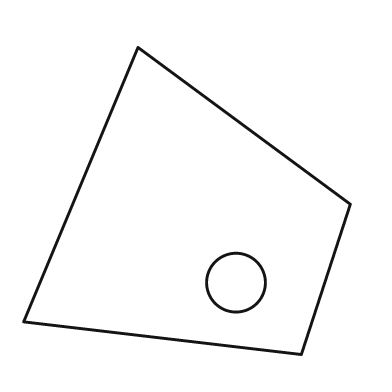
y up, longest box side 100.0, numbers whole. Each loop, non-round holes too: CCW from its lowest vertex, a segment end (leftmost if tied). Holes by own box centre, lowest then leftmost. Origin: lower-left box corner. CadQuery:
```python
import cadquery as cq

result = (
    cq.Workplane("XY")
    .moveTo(85.0, 0.0)
    .lineTo(100.0, 46.0)
    .lineTo(35.0, 94.0)
    .lineTo(0.0, 10.0)
    .close()
    .moveTo(65.0, 22.0)
    .circle(9.0)
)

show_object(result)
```